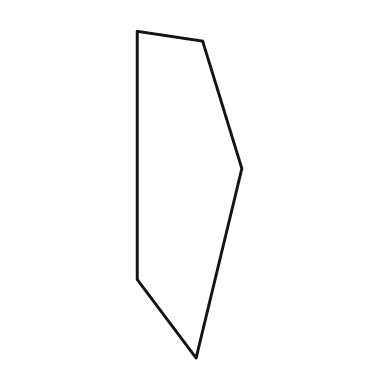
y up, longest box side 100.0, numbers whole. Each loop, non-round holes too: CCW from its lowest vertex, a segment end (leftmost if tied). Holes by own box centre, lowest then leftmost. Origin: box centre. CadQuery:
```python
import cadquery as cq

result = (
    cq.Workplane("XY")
    .moveTo(2.0, -50.0)
    .lineTo(16.0, 8.0)
    .lineTo(4.0, 47.0)
    .lineTo(-16.0, 50.0)
    .lineTo(-16.0, -26.0)
    .close()
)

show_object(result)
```